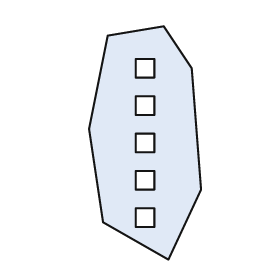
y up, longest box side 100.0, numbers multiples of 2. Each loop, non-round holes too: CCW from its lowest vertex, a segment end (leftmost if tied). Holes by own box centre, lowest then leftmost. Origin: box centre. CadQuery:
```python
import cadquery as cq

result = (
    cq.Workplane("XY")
    .moveTo(10.0, -50.0)
    .lineTo(24.0, -20.0)
    .lineTo(20.0, 32.0)
    .lineTo(8.0, 50.0)
    .lineTo(-16.0, 46.0)
    .lineTo(-24.0, 6.0)
    .lineTo(-18.0, -34.0)
    .close()
    .moveTo(-4.0, -36.0)
    .lineTo(4.0, -36.0)
    .lineTo(4.0, -28.0)
    .lineTo(-4.0, -28.0)
    .close()
    .moveTo(-4.0, -20.0)
    .lineTo(4.0, -20.0)
    .lineTo(4.0, -12.0)
    .lineTo(-4.0, -12.0)
    .close()
    .moveTo(-4.0, -4.0)
    .lineTo(4.0, -4.0)
    .lineTo(4.0, 4.0)
    .lineTo(-4.0, 4.0)
    .close()
    .moveTo(-4.0, 12.0)
    .lineTo(4.0, 12.0)
    .lineTo(4.0, 20.0)
    .lineTo(-4.0, 20.0)
    .close()
    .moveTo(-4.0, 28.0)
    .lineTo(4.0, 28.0)
    .lineTo(4.0, 36.0)
    .lineTo(-4.0, 36.0)
    .close()
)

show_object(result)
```